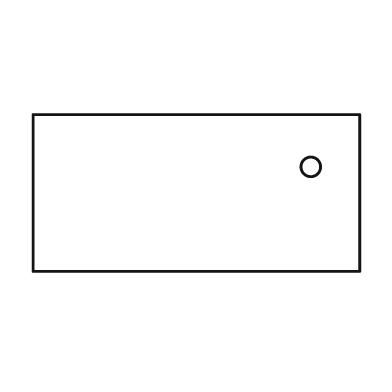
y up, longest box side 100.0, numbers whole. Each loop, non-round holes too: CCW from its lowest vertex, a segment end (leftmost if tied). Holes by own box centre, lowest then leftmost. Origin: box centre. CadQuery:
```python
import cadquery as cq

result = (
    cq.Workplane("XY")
    .moveTo(-50.0, -24.0)
    .lineTo(50.0, -24.0)
    .lineTo(50.0, 24.0)
    .lineTo(-50.0, 24.0)
    .close()
    .moveTo(35.0, 8.0)
    .circle(3.0)
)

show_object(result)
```